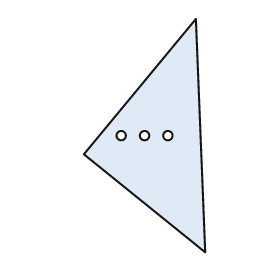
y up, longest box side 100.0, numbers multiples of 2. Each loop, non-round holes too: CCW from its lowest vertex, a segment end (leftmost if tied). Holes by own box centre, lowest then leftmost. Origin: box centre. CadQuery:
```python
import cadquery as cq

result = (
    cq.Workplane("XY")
    .moveTo(26.0, -50.0)
    .lineTo(22.0, 50.0)
    .lineTo(-26.0, -8.0)
    .close()
    .moveTo(-10.0, 0.0)
    .circle(2.0)
    .moveTo(0.0, 0.0)
    .circle(2.0)
    .moveTo(10.0, 0.0)
    .circle(2.0)
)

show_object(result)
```